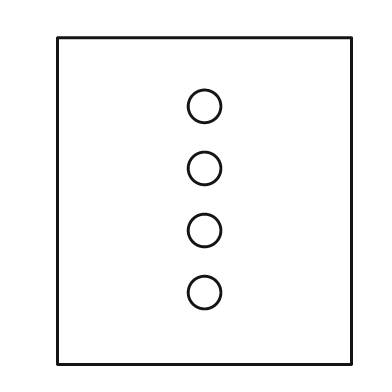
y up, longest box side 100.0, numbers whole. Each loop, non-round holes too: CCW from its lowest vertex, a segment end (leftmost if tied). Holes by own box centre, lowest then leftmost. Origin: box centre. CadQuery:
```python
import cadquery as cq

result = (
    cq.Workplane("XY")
    .moveTo(-45.0, -50.0)
    .lineTo(45.0, -50.0)
    .lineTo(45.0, 50.0)
    .lineTo(-45.0, 50.0)
    .close()
    .moveTo(0.0, -28.0)
    .circle(5.0)
    .moveTo(0.0, -9.0)
    .circle(5.0)
    .moveTo(0.0, 10.0)
    .circle(5.0)
    .moveTo(0.0, 29.0)
    .circle(5.0)
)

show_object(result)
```